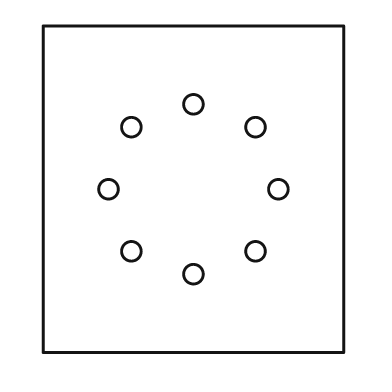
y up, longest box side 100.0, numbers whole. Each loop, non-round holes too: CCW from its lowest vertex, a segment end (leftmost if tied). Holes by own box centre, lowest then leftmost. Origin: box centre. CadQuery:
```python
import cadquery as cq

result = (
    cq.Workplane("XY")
    .moveTo(-46.0, -50.0)
    .lineTo(46.0, -50.0)
    .lineTo(46.0, 50.0)
    .lineTo(-46.0, 50.0)
    .close()
    .moveTo(0.0, -26.0)
    .circle(3.0)
    .moveTo(-19.0, -19.0)
    .circle(3.0)
    .moveTo(19.0, -19.0)
    .circle(3.0)
    .moveTo(-26.0, 0.0)
    .circle(3.0)
    .moveTo(26.0, 0.0)
    .circle(3.0)
    .moveTo(-19.0, 19.0)
    .circle(3.0)
    .moveTo(19.0, 19.0)
    .circle(3.0)
    .moveTo(0.0, 26.0)
    .circle(3.0)
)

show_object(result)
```